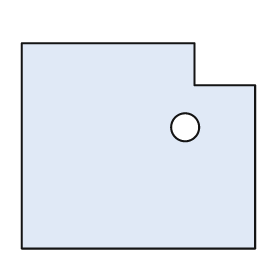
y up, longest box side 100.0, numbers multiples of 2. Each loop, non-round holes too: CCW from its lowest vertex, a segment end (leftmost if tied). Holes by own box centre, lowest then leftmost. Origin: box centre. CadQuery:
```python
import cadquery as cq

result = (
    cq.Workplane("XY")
    .moveTo(-50.0, -44.0)
    .lineTo(50.0, -44.0)
    .lineTo(50.0, 26.0)
    .lineTo(24.0, 26.0)
    .lineTo(24.0, 44.0)
    .lineTo(-50.0, 44.0)
    .close()
    .moveTo(20.0, 8.0)
    .circle(6.0)
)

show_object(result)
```